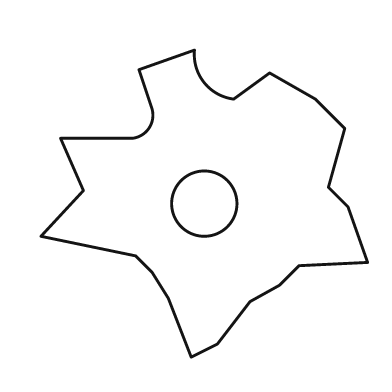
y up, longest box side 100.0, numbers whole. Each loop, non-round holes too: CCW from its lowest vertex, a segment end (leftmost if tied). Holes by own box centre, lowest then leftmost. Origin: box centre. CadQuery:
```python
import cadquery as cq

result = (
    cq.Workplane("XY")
    .moveTo(-4.0, -47.0)
    .lineTo(4.0, -43.0)
    .lineTo(14.0, -30.0)
    .lineTo(23.0, -25.0)
    .lineTo(29.0, -19.0)
    .lineTo(50.0, -18.0)
    .lineTo(44.0, -1.0)
    .lineTo(38.0, 5.0)
    .lineTo(43.0, 23.0)
    .lineTo(34.0, 32.0)
    .lineTo(20.0, 40.0)
    .lineTo(9.0, 32.0)
    .threePointArc((0.0, 37.0), (-3.0, 47.0))
    .lineTo(-20.0, 41.0)
    .lineTo(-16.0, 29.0)
    .threePointArc((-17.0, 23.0), (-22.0, 20.0))
    .lineTo(-44.0, 20.0)
    .lineTo(-37.0, 4.0)
    .lineTo(-50.0, -10.0)
    .lineTo(-21.0, -16.0)
    .lineTo(-16.0, -21.0)
    .lineTo(-11.0, -29.0)
    .close()
    .moveTo(0.0, 0.0)
    .circle(10.0)
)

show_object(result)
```